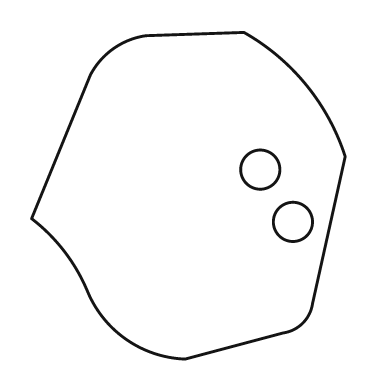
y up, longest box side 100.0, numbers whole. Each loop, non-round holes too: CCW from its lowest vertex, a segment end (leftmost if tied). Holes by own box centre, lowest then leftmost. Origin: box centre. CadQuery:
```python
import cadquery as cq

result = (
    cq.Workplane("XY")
    .moveTo(-1.0, -50.0)
    .lineTo(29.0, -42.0)
    .threePointArc((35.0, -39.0), (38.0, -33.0))
    .lineTo(48.0, 12.0)
    .threePointArc((36.0, 34.0), (17.0, 50.0))
    .lineTo(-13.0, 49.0)
    .threePointArc((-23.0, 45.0), (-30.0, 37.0))
    .lineTo(-48.0, -7.0)
    .threePointArc((-38.0, -17.0), (-31.0, -29.0))
    .threePointArc((-19.0, -44.0), (-1.0, -50.0))
    .close()
    .moveTo(32.0, -8.0)
    .circle(6.0)
    .moveTo(22.0, 8.0)
    .circle(6.0)
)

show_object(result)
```